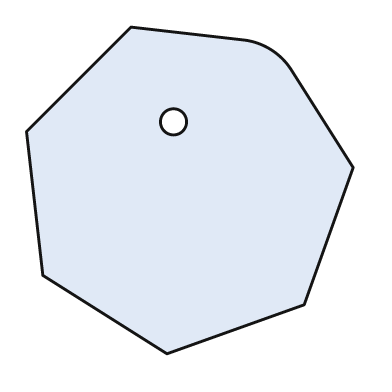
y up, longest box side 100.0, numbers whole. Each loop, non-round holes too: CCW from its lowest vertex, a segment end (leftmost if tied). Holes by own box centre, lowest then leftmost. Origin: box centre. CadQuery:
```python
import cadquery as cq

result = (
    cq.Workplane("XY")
    .moveTo(-7.0, -50.0)
    .lineTo(35.0, -35.0)
    .lineTo(50.0, 7.0)
    .lineTo(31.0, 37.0)
    .threePointArc((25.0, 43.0), (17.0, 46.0))
    .lineTo(-18.0, 50.0)
    .lineTo(-50.0, 18.0)
    .lineTo(-45.0, -26.0)
    .close()
    .moveTo(-5.0, 21.0)
    .circle(4.0)
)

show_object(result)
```